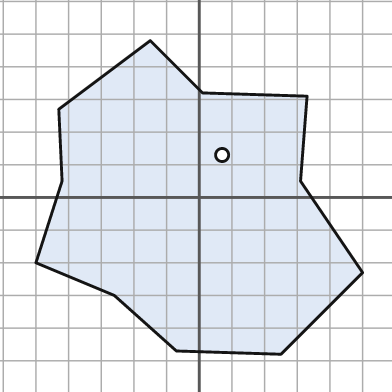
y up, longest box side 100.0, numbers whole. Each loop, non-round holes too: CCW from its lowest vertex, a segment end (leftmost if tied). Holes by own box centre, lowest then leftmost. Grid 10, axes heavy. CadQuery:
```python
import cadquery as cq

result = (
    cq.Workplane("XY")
    .moveTo(25.0, -48.0)
    .lineTo(50.0, -23.0)
    .lineTo(31.0, 5.0)
    .lineTo(33.0, 31.0)
    .lineTo(1.0, 32.0)
    .lineTo(-15.0, 48.0)
    .lineTo(-43.0, 27.0)
    .lineTo(-42.0, 5.0)
    .lineTo(-50.0, -20.0)
    .lineTo(-26.0, -30.0)
    .lineTo(-7.0, -47.0)
    .close()
    .moveTo(7.0, 13.0)
    .circle(2.0)
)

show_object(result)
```